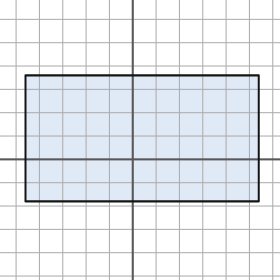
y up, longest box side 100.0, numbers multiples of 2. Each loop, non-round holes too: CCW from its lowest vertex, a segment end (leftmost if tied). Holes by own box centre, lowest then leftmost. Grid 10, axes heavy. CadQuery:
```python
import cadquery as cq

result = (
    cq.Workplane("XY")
    .moveTo(-46.0, -18.0)
    .lineTo(54.0, -18.0)
    .lineTo(54.0, 36.0)
    .lineTo(-46.0, 36.0)
    .close()
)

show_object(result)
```